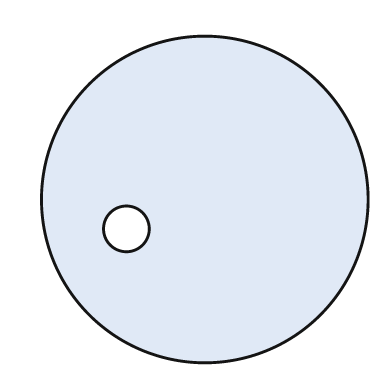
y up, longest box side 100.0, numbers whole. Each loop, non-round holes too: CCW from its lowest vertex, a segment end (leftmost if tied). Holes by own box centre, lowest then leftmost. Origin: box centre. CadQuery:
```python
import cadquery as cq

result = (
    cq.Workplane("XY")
    .moveTo(0.0, 0.0)
    .circle(50.0)
    .moveTo(-24.0, -9.0)
    .circle(7.0)
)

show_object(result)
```